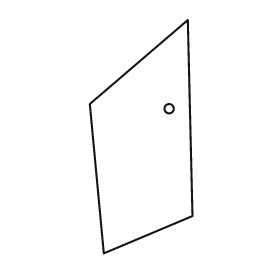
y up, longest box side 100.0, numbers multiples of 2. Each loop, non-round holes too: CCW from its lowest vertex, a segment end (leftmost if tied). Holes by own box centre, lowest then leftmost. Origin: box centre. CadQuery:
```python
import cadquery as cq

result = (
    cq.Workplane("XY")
    .moveTo(-16.0, -50.0)
    .lineTo(22.0, -34.0)
    .lineTo(20.0, 50.0)
    .lineTo(-22.0, 14.0)
    .close()
    .moveTo(12.0, 12.0)
    .circle(2.0)
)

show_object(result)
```